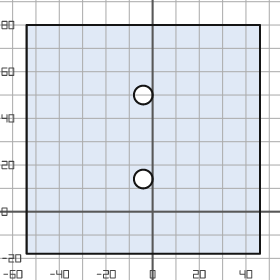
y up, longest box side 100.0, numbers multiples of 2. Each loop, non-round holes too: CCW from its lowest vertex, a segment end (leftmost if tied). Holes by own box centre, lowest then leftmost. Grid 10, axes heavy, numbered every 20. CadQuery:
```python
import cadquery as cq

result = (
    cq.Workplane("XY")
    .moveTo(-54.0, -18.0)
    .lineTo(46.0, -18.0)
    .lineTo(46.0, 80.0)
    .lineTo(-54.0, 80.0)
    .close()
    .moveTo(-4.0, 14.0)
    .circle(4.0)
    .moveTo(-4.0, 50.0)
    .circle(4.0)
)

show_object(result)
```